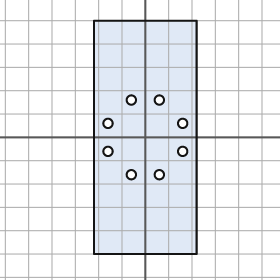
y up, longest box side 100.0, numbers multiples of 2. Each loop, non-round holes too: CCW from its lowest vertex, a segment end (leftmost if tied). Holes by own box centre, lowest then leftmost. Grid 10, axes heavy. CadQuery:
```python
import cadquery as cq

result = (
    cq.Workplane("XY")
    .moveTo(-22.0, -50.0)
    .lineTo(22.0, -50.0)
    .lineTo(22.0, 50.0)
    .lineTo(-22.0, 50.0)
    .close()
    .moveTo(-6.0, -16.0)
    .circle(2.0)
    .moveTo(6.0, -16.0)
    .circle(2.0)
    .moveTo(-16.0, -6.0)
    .circle(2.0)
    .moveTo(16.0, -6.0)
    .circle(2.0)
    .moveTo(-16.0, 6.0)
    .circle(2.0)
    .moveTo(16.0, 6.0)
    .circle(2.0)
    .moveTo(-6.0, 16.0)
    .circle(2.0)
    .moveTo(6.0, 16.0)
    .circle(2.0)
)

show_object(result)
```